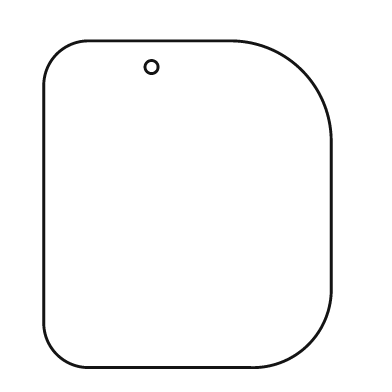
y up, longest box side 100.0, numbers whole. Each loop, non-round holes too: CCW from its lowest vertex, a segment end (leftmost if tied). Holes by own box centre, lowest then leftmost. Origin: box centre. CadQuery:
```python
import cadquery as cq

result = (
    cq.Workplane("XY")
    .moveTo(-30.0, -50.0)
    .lineTo(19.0, -50.0)
    .threePointArc((37.0, -43.0), (44.0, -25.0))
    .lineTo(44.0, 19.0)
    .threePointArc((35.0, 41.0), (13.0, 50.0))
    .lineTo(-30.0, 50.0)
    .threePointArc((-40.0, 46.0), (-44.0, 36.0))
    .lineTo(-44.0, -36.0)
    .threePointArc((-40.0, -46.0), (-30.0, -50.0))
    .close()
    .moveTo(-11.0, 42.0)
    .circle(2.0)
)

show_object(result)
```